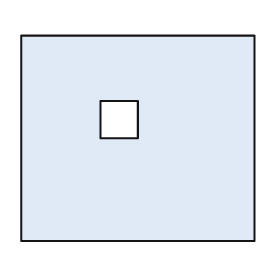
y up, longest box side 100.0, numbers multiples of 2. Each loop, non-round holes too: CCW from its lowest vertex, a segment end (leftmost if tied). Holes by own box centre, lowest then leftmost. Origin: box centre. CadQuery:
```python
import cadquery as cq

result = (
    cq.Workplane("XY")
    .moveTo(-50.0, -44.0)
    .lineTo(50.0, -44.0)
    .lineTo(50.0, 44.0)
    .lineTo(-50.0, 44.0)
    .close()
    .moveTo(-16.0, 0.0)
    .lineTo(0.0, 0.0)
    .lineTo(0.0, 16.0)
    .lineTo(-16.0, 16.0)
    .close()
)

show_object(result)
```